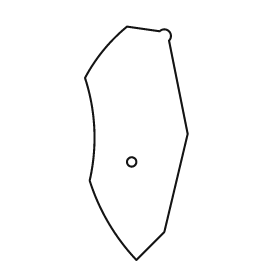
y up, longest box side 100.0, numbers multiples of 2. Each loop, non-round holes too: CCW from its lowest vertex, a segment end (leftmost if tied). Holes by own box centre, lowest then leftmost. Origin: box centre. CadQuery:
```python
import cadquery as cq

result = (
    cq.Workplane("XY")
    .moveTo(0.0, -50.0)
    .lineTo(12.0, -38.0)
    .lineTo(22.0, 4.0)
    .lineTo(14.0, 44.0)
    .threePointArc((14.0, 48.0), (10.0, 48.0))
    .lineTo(-4.0, 50.0)
    .threePointArc((-14.0, 40.0), (-22.0, 28.0))
    .threePointArc((-18.0, 6.0), (-20.0, -16.0))
    .threePointArc((-12.0, -34.0), (0.0, -50.0))
    .close()
    .moveTo(-2.0, -8.0)
    .circle(2.0)
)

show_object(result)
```